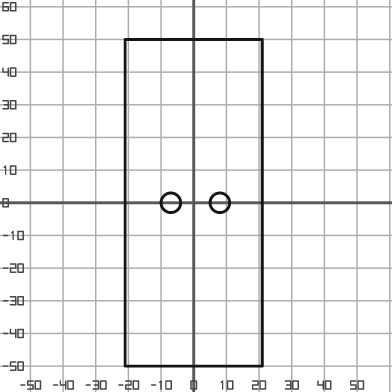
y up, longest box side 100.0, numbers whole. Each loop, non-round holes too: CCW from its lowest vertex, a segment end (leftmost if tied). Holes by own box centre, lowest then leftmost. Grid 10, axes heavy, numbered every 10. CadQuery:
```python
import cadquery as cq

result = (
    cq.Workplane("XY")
    .moveTo(-21.0, -50.0)
    .lineTo(21.0, -50.0)
    .lineTo(21.0, 50.0)
    .lineTo(-21.0, 50.0)
    .close()
    .moveTo(-7.0, 0.0)
    .circle(3.0)
    .moveTo(8.0, 0.0)
    .circle(3.0)
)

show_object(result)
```